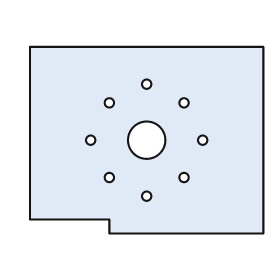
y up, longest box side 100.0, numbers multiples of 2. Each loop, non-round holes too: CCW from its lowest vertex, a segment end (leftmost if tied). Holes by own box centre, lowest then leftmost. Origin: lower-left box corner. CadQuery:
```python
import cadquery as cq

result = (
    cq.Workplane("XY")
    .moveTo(34.0, 0.0)
    .lineTo(100.0, 0.0)
    .lineTo(100.0, 80.0)
    .lineTo(0.0, 80.0)
    .lineTo(0.0, 6.0)
    .lineTo(34.0, 6.0)
    .close()
    .moveTo(50.0, 16.0)
    .circle(2.0)
    .moveTo(34.0, 24.0)
    .circle(2.0)
    .moveTo(66.0, 24.0)
    .circle(2.0)
    .moveTo(26.0, 40.0)
    .circle(2.0)
    .moveTo(50.0, 40.0)
    .circle(8.0)
    .moveTo(74.0, 40.0)
    .circle(2.0)
    .moveTo(34.0, 56.0)
    .circle(2.0)
    .moveTo(66.0, 56.0)
    .circle(2.0)
    .moveTo(50.0, 64.0)
    .circle(2.0)
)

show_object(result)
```